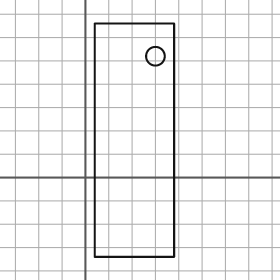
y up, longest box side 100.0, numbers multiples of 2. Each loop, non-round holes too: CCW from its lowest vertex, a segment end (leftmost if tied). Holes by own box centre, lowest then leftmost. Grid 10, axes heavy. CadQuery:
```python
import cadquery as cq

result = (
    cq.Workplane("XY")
    .moveTo(4.0, -34.0)
    .lineTo(38.0, -34.0)
    .lineTo(38.0, 66.0)
    .lineTo(4.0, 66.0)
    .close()
    .moveTo(30.0, 52.0)
    .circle(4.0)
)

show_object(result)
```